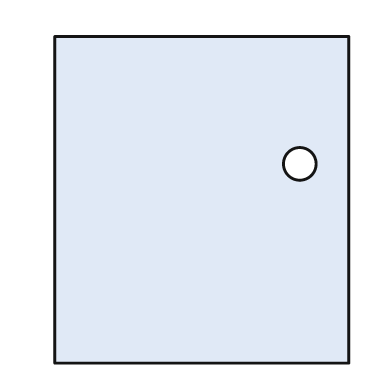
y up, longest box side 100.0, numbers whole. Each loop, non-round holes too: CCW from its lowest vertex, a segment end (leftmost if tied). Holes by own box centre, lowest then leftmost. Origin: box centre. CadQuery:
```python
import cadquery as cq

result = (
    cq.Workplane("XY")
    .moveTo(-45.0, -50.0)
    .lineTo(45.0, -50.0)
    .lineTo(45.0, 50.0)
    .lineTo(-45.0, 50.0)
    .close()
    .moveTo(30.0, 11.0)
    .circle(5.0)
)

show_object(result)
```